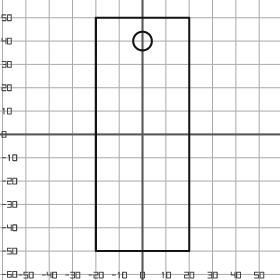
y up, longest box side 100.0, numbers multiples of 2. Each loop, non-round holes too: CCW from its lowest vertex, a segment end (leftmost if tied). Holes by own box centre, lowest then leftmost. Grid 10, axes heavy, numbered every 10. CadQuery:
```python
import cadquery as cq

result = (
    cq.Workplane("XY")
    .moveTo(-20.0, -50.0)
    .lineTo(20.0, -50.0)
    .lineTo(20.0, 50.0)
    .lineTo(-20.0, 50.0)
    .close()
    .moveTo(0.0, 40.0)
    .circle(4.0)
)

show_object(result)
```